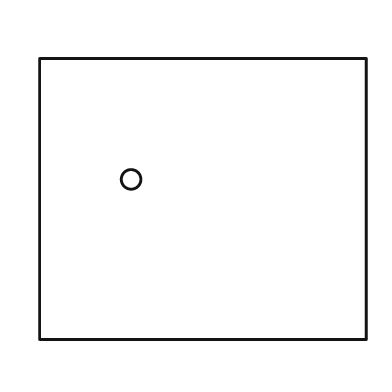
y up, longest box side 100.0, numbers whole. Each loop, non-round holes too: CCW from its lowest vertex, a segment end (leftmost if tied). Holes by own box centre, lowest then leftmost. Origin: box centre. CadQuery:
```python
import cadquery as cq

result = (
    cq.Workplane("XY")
    .moveTo(-50.0, -43.0)
    .lineTo(50.0, -43.0)
    .lineTo(50.0, 43.0)
    .lineTo(-50.0, 43.0)
    .close()
    .moveTo(-22.0, 6.0)
    .circle(3.0)
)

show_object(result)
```